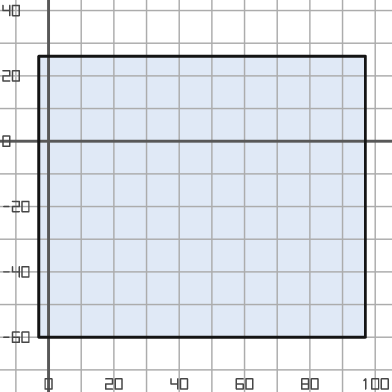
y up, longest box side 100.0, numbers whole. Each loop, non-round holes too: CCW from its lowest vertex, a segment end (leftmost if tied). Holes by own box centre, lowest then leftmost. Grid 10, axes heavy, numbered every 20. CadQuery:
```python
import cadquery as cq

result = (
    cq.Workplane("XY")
    .moveTo(-3.0, -60.0)
    .lineTo(97.0, -60.0)
    .lineTo(97.0, 26.0)
    .lineTo(-3.0, 26.0)
    .close()
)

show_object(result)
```